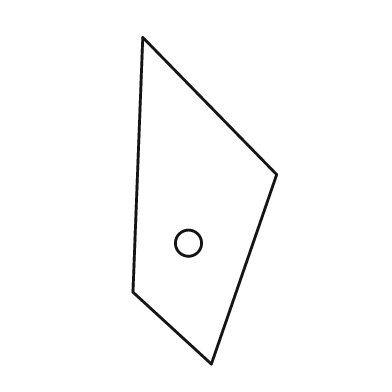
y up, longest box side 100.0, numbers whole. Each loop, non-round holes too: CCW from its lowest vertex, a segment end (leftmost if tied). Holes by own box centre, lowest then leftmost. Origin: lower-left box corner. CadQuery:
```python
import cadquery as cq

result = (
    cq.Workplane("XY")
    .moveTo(24.0, 0.0)
    .lineTo(44.0, 58.0)
    .lineTo(3.0, 100.0)
    .lineTo(0.0, 22.0)
    .close()
    .moveTo(17.0, 37.0)
    .circle(4.0)
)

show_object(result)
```